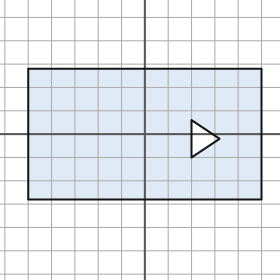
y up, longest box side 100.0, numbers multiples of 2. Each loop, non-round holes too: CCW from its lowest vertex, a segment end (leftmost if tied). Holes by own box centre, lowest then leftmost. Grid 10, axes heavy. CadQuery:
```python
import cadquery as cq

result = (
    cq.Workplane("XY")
    .moveTo(-50.0, -28.0)
    .lineTo(50.0, -28.0)
    .lineTo(50.0, 28.0)
    .lineTo(-50.0, 28.0)
    .close()
    .moveTo(20.0, -10.0)
    .lineTo(32.0, -2.0)
    .lineTo(20.0, 6.0)
    .close()
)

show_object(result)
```